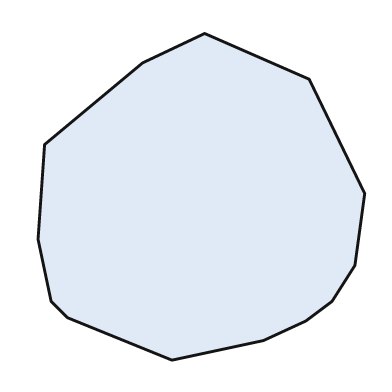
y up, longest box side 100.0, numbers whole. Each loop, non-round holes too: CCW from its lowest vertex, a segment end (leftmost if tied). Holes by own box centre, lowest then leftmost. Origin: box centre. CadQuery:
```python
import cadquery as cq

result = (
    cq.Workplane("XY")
    .moveTo(-9.0, -50.0)
    .lineTo(19.0, -44.0)
    .lineTo(32.0, -38.0)
    .lineTo(40.0, -32.0)
    .lineTo(47.0, -21.0)
    .lineTo(50.0, 1.0)
    .lineTo(33.0, 36.0)
    .lineTo(1.0, 50.0)
    .lineTo(-18.0, 41.0)
    .lineTo(-48.0, 16.0)
    .lineTo(-50.0, -13.0)
    .lineTo(-46.0, -32.0)
    .lineTo(-41.0, -37.0)
    .close()
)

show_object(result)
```